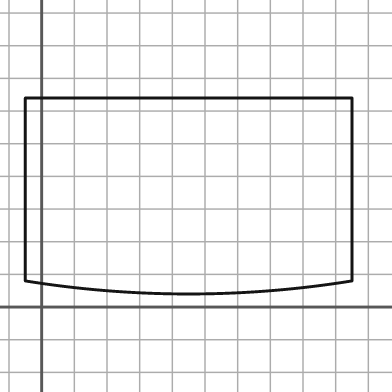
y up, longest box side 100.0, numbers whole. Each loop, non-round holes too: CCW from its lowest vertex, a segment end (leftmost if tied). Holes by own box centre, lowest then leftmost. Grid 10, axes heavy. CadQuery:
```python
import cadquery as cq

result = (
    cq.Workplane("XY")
    .moveTo(-5.0, 8.0)
    .threePointArc((45.0, 4.0), (95.0, 8.0))
    .lineTo(95.0, 64.0)
    .lineTo(-5.0, 64.0)
    .close()
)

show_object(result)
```